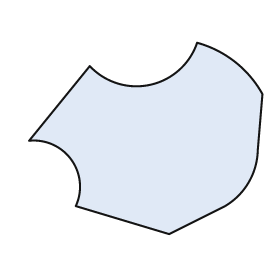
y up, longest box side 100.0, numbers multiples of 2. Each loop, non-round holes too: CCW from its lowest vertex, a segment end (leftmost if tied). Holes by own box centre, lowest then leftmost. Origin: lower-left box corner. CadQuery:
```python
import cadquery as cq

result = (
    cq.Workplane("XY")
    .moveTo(60.0, 0.0)
    .lineTo(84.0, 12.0)
    .threePointArc((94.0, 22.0), (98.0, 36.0))
    .lineTo(100.0, 60.0)
    .threePointArc((88.0, 74.0), (72.0, 82.0))
    .threePointArc((52.0, 64.0), (26.0, 72.0))
    .lineTo(0.0, 40.0)
    .threePointArc((18.0, 32.0), (20.0, 12.0))
    .close()
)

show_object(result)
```